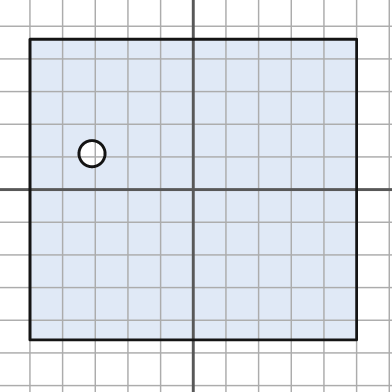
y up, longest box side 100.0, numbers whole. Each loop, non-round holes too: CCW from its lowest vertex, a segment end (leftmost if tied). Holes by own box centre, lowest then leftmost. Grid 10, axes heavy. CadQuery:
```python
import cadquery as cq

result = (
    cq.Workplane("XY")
    .moveTo(-50.0, -46.0)
    .lineTo(50.0, -46.0)
    .lineTo(50.0, 46.0)
    .lineTo(-50.0, 46.0)
    .close()
    .moveTo(-31.0, 11.0)
    .circle(4.0)
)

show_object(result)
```